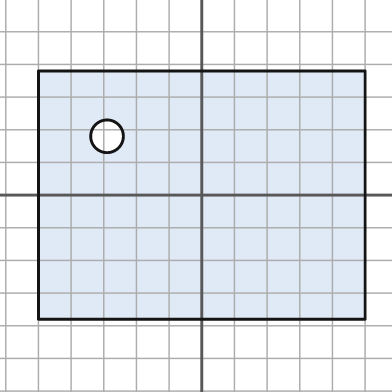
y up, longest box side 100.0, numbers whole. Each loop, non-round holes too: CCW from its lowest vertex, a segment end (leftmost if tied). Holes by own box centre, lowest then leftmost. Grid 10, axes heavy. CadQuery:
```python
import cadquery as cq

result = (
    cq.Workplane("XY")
    .moveTo(-50.0, -38.0)
    .lineTo(50.0, -38.0)
    .lineTo(50.0, 38.0)
    .lineTo(-50.0, 38.0)
    .close()
    .moveTo(-29.0, 18.0)
    .circle(5.0)
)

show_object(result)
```